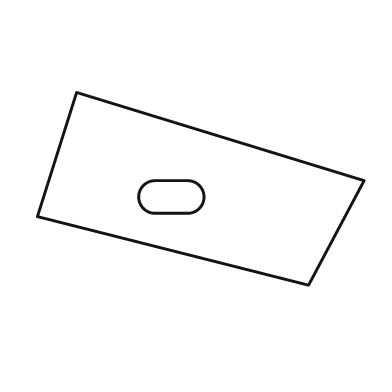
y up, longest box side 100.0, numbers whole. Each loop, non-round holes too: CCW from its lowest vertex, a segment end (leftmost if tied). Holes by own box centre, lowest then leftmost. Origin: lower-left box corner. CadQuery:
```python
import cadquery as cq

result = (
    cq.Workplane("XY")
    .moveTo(83.0, 0.0)
    .lineTo(100.0, 32.0)
    .lineTo(12.0, 59.0)
    .lineTo(0.0, 21.0)
    .close()
    .moveTo(36.0, 22.0)
    .lineTo(46.0, 22.0)
    .threePointArc((51.0, 27.0), (46.0, 32.0))
    .lineTo(36.0, 32.0)
    .threePointArc((31.0, 27.0), (36.0, 22.0))
    .close()
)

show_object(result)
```